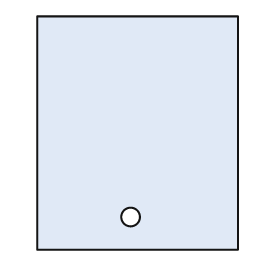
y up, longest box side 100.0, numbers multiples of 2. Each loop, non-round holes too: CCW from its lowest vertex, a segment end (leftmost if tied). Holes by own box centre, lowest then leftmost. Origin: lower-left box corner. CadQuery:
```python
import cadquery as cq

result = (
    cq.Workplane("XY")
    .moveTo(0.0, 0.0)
    .lineTo(86.0, 0.0)
    .lineTo(86.0, 100.0)
    .lineTo(0.0, 100.0)
    .close()
    .moveTo(40.0, 14.0)
    .circle(4.0)
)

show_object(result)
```